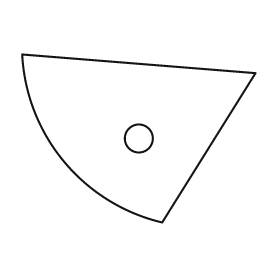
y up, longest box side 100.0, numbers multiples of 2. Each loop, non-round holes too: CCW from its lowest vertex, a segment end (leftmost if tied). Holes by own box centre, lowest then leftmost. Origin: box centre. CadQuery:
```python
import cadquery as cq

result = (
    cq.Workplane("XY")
    .moveTo(10.0, -36.0)
    .lineTo(50.0, 28.0)
    .lineTo(-50.0, 36.0)
    .threePointArc((-32.0, -10.0), (10.0, -36.0))
    .close()
    .moveTo(0.0, 0.0)
    .circle(6.0)
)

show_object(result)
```